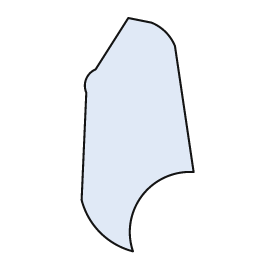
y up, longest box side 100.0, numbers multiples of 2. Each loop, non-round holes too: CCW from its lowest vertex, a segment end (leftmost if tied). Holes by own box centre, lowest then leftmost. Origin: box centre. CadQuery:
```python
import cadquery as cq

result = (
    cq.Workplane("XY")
    .moveTo(-2.0, -50.0)
    .threePointArc((2.0, -26.0), (24.0, -16.0))
    .lineTo(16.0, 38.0)
    .threePointArc((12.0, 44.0), (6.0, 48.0))
    .lineTo(-4.0, 50.0)
    .lineTo(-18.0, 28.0)
    .threePointArc((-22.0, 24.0), (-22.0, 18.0))
    .lineTo(-24.0, -28.0)
    .threePointArc((-16.0, -42.0), (-2.0, -50.0))
    .close()
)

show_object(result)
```